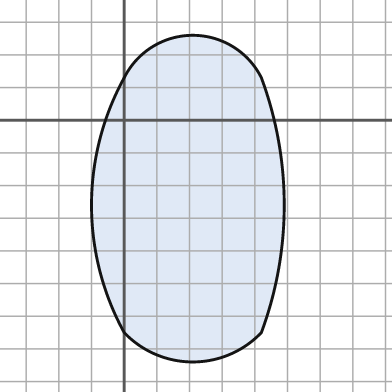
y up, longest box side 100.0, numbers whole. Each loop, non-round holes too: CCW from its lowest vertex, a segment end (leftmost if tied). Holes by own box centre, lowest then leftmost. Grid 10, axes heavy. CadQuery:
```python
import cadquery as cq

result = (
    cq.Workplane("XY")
    .moveTo(0.0, -65.0)
    .threePointArc((21.0, -74.0), (42.0, -65.0))
    .threePointArc((49.0, -26.0), (42.0, 13.0))
    .threePointArc((21.0, 26.0), (0.0, 13.0))
    .threePointArc((-10.0, -26.0), (0.0, -65.0))
    .close()
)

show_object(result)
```